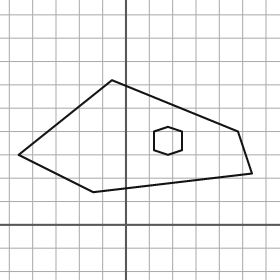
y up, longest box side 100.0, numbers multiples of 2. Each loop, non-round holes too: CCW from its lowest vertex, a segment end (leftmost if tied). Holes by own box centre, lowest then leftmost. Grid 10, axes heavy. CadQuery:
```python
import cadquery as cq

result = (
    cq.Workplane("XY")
    .moveTo(-14.0, 14.0)
    .lineTo(54.0, 22.0)
    .lineTo(48.0, 40.0)
    .lineTo(-6.0, 62.0)
    .lineTo(-46.0, 30.0)
    .close()
    .moveTo(18.0, 30.0)
    .lineTo(24.0, 32.0)
    .lineTo(24.0, 40.0)
    .lineTo(18.0, 42.0)
    .lineTo(12.0, 40.0)
    .lineTo(12.0, 32.0)
    .close()
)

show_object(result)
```